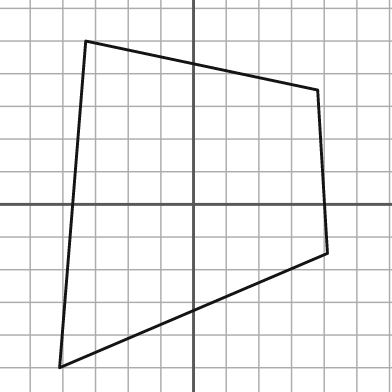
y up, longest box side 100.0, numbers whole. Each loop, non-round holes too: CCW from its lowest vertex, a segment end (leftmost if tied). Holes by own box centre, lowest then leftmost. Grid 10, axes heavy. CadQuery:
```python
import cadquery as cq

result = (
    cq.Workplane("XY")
    .moveTo(-41.0, -50.0)
    .lineTo(41.0, -15.0)
    .lineTo(38.0, 35.0)
    .lineTo(-33.0, 50.0)
    .close()
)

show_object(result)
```